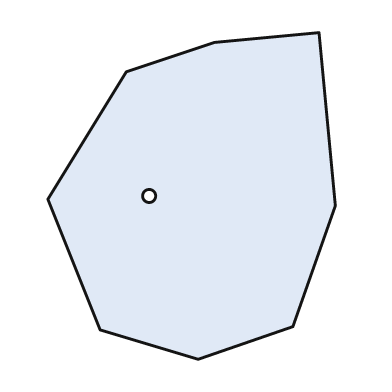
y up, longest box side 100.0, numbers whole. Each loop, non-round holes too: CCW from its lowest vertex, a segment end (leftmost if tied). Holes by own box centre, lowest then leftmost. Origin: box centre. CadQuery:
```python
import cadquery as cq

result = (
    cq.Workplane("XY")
    .moveTo(2.0, -50.0)
    .lineTo(31.0, -40.0)
    .lineTo(44.0, -3.0)
    .lineTo(39.0, 50.0)
    .lineTo(7.0, 47.0)
    .lineTo(-20.0, 38.0)
    .lineTo(-44.0, -1.0)
    .lineTo(-28.0, -41.0)
    .close()
    .moveTo(-13.0, 0.0)
    .circle(2.0)
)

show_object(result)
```